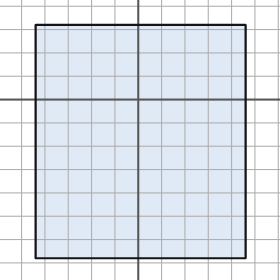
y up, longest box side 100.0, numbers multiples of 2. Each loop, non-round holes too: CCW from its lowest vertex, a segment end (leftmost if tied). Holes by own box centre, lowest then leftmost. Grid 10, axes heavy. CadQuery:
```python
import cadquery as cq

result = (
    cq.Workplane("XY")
    .moveTo(-44.0, -68.0)
    .lineTo(46.0, -68.0)
    .lineTo(46.0, 32.0)
    .lineTo(-44.0, 32.0)
    .close()
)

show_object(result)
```